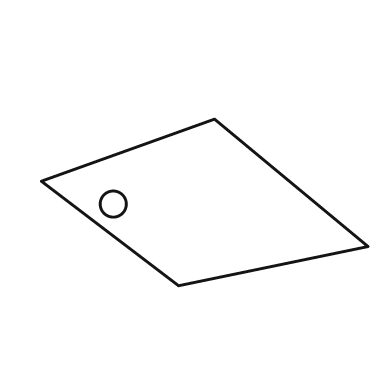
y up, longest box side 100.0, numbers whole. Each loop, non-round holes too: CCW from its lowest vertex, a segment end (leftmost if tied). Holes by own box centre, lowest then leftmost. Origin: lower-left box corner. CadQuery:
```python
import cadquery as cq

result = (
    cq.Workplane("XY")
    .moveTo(42.0, 0.0)
    .lineTo(100.0, 12.0)
    .lineTo(53.0, 51.0)
    .lineTo(0.0, 32.0)
    .close()
    .moveTo(22.0, 25.0)
    .circle(4.0)
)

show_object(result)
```